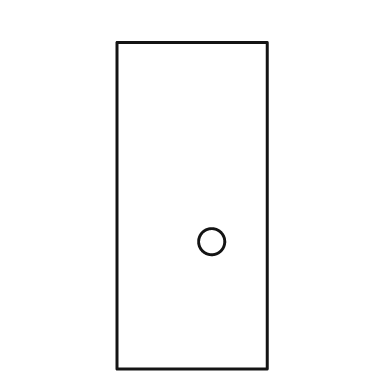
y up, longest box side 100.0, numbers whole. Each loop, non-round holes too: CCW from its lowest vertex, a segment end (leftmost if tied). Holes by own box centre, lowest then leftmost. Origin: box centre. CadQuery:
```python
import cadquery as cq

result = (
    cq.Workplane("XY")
    .moveTo(-23.0, -50.0)
    .lineTo(23.0, -50.0)
    .lineTo(23.0, 50.0)
    .lineTo(-23.0, 50.0)
    .close()
    .moveTo(6.0, -11.0)
    .circle(4.0)
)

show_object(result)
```